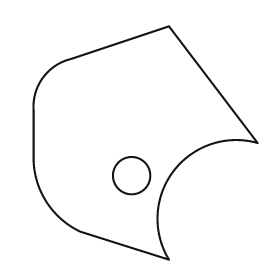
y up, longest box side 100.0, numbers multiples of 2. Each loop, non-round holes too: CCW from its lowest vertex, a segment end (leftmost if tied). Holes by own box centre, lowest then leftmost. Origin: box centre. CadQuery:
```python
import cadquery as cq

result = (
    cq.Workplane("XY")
    .moveTo(10.0, -50.0)
    .threePointArc((12.0, -12.0), (48.0, 0.0))
    .lineTo(10.0, 50.0)
    .lineTo(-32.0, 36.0)
    .threePointArc((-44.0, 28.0), (-48.0, 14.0))
    .lineTo(-48.0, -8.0)
    .threePointArc((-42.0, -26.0), (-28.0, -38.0))
    .close()
    .moveTo(-6.0, -14.0)
    .circle(8.0)
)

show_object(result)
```